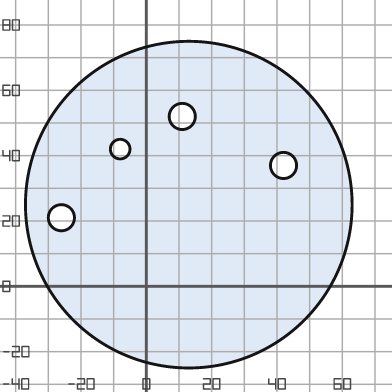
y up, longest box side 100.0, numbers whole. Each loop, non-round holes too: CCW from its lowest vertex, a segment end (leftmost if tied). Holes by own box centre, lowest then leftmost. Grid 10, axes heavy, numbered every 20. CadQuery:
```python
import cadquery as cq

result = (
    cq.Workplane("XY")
    .moveTo(13.0, 25.0)
    .circle(50.0)
    .moveTo(-26.0, 21.0)
    .circle(4.0)
    .moveTo(42.0, 37.0)
    .circle(4.0)
    .moveTo(-8.0, 42.0)
    .circle(3.0)
    .moveTo(11.0, 52.0)
    .circle(4.0)
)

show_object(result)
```